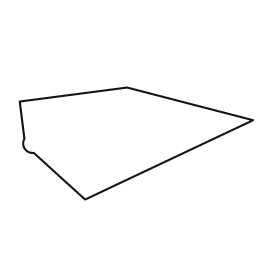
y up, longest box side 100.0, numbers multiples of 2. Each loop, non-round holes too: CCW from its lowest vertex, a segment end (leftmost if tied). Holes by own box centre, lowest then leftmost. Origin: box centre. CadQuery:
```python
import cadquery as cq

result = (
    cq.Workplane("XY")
    .moveTo(-22.0, -24.0)
    .lineTo(50.0, 10.0)
    .lineTo(-4.0, 24.0)
    .lineTo(-50.0, 18.0)
    .lineTo(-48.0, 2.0)
    .threePointArc((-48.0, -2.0), (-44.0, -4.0))
    .close()
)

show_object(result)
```